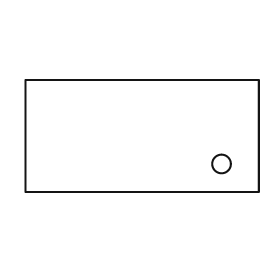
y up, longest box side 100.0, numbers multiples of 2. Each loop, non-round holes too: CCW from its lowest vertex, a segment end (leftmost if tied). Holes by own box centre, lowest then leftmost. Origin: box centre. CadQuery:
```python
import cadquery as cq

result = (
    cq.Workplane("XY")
    .moveTo(-50.0, -24.0)
    .lineTo(50.0, -24.0)
    .lineTo(50.0, 24.0)
    .lineTo(-50.0, 24.0)
    .close()
    .moveTo(34.0, -12.0)
    .circle(4.0)
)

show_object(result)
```